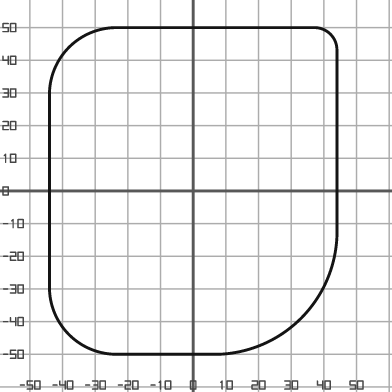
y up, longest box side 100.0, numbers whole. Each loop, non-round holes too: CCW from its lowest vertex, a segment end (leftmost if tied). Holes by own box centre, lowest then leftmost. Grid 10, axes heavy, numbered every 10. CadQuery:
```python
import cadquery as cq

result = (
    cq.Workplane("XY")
    .moveTo(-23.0, -50.0)
    .lineTo(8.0, -50.0)
    .threePointArc((33.0, -39.0), (44.0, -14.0))
    .lineTo(44.0, 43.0)
    .threePointArc((42.0, 48.0), (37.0, 50.0))
    .lineTo(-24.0, 50.0)
    .threePointArc((-38.0, 44.0), (-44.0, 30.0))
    .lineTo(-44.0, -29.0)
    .threePointArc((-38.0, -44.0), (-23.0, -50.0))
    .close()
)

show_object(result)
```